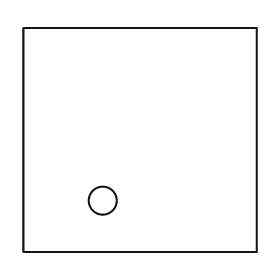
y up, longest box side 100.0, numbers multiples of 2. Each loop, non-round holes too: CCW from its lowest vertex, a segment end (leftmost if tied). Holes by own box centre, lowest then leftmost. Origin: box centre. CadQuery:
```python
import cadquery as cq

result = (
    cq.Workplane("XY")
    .moveTo(-50.0, -48.0)
    .lineTo(50.0, -48.0)
    .lineTo(50.0, 48.0)
    .lineTo(-50.0, 48.0)
    .close()
    .moveTo(-16.0, -26.0)
    .circle(6.0)
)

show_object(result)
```